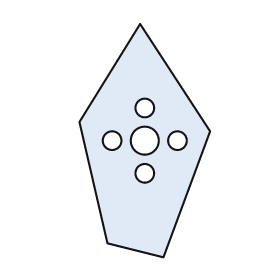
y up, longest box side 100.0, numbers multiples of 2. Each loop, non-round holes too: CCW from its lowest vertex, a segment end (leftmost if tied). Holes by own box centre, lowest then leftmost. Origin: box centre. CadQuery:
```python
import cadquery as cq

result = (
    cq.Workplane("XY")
    .moveTo(8.0, -50.0)
    .lineTo(28.0, 4.0)
    .lineTo(-2.0, 50.0)
    .lineTo(-28.0, 8.0)
    .lineTo(-16.0, -44.0)
    .close()
    .moveTo(0.0, -14.0)
    .circle(4.0)
    .moveTo(-14.0, 0.0)
    .circle(4.0)
    .moveTo(0.0, 0.0)
    .circle(6.0)
    .moveTo(14.0, 0.0)
    .circle(4.0)
    .moveTo(0.0, 14.0)
    .circle(4.0)
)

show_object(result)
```